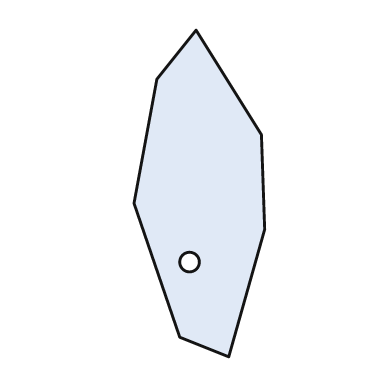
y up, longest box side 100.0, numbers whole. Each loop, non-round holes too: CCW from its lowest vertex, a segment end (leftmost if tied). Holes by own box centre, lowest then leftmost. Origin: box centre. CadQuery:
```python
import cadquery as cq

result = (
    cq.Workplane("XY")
    .moveTo(9.0, -50.0)
    .lineTo(20.0, -11.0)
    .lineTo(19.0, 18.0)
    .lineTo(-1.0, 50.0)
    .lineTo(-13.0, 35.0)
    .lineTo(-20.0, -3.0)
    .lineTo(-6.0, -44.0)
    .close()
    .moveTo(-3.0, -21.0)
    .circle(3.0)
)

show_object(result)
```